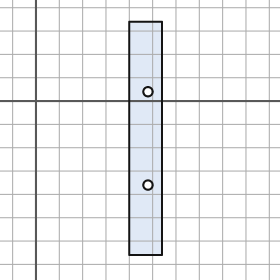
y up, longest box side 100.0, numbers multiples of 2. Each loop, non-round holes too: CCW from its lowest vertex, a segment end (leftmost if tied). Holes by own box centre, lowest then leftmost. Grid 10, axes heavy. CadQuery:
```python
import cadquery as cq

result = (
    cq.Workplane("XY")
    .moveTo(40.0, -66.0)
    .lineTo(54.0, -66.0)
    .lineTo(54.0, 34.0)
    .lineTo(40.0, 34.0)
    .close()
    .moveTo(48.0, -36.0)
    .circle(2.0)
    .moveTo(48.0, 4.0)
    .circle(2.0)
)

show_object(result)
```